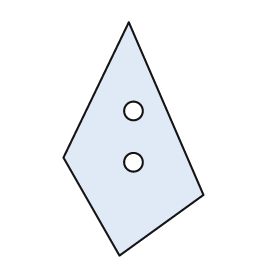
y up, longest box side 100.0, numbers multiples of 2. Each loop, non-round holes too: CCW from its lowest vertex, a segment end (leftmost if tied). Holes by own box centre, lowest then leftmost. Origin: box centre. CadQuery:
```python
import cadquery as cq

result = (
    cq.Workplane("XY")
    .moveTo(-6.0, -50.0)
    .lineTo(30.0, -24.0)
    .lineTo(-2.0, 50.0)
    .lineTo(-30.0, -8.0)
    .close()
    .moveTo(0.0, -10.0)
    .circle(4.0)
    .moveTo(0.0, 12.0)
    .circle(4.0)
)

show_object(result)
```